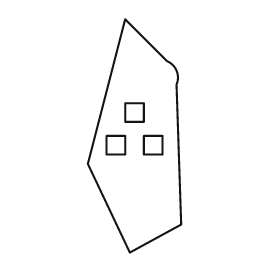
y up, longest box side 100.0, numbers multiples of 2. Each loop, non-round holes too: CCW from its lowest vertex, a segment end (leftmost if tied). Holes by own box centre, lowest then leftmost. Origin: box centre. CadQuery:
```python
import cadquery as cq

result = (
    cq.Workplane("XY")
    .moveTo(-2.0, -50.0)
    .lineTo(20.0, -38.0)
    .lineTo(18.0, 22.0)
    .threePointArc((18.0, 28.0), (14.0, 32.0))
    .lineTo(-4.0, 50.0)
    .lineTo(-20.0, -12.0)
    .close()
    .moveTo(-12.0, -8.0)
    .lineTo(-4.0, -8.0)
    .lineTo(-4.0, 0.0)
    .lineTo(-12.0, 0.0)
    .close()
    .moveTo(4.0, -8.0)
    .lineTo(12.0, -8.0)
    .lineTo(12.0, 0.0)
    .lineTo(4.0, 0.0)
    .close()
    .moveTo(-4.0, 6.0)
    .lineTo(4.0, 6.0)
    .lineTo(4.0, 14.0)
    .lineTo(-4.0, 14.0)
    .close()
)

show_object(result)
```